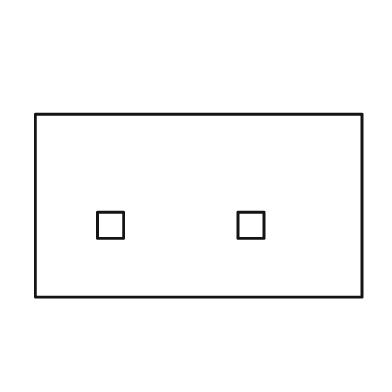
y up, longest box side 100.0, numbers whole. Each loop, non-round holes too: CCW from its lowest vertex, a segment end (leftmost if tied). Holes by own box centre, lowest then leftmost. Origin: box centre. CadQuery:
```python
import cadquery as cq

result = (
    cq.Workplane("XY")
    .moveTo(-50.0, -28.0)
    .lineTo(50.0, -28.0)
    .lineTo(50.0, 28.0)
    .lineTo(-50.0, 28.0)
    .close()
    .moveTo(-31.0, -10.0)
    .lineTo(-23.0, -10.0)
    .lineTo(-23.0, -2.0)
    .lineTo(-31.0, -2.0)
    .close()
    .moveTo(12.0, -10.0)
    .lineTo(20.0, -10.0)
    .lineTo(20.0, -2.0)
    .lineTo(12.0, -2.0)
    .close()
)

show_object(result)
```